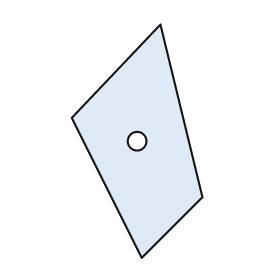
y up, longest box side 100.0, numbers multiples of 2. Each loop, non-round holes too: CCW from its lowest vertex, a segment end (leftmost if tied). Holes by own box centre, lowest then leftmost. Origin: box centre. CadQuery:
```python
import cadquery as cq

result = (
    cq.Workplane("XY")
    .moveTo(2.0, -50.0)
    .lineTo(28.0, -24.0)
    .lineTo(10.0, 50.0)
    .lineTo(-28.0, 10.0)
    .close()
    .moveTo(0.0, 0.0)
    .circle(4.0)
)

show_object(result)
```